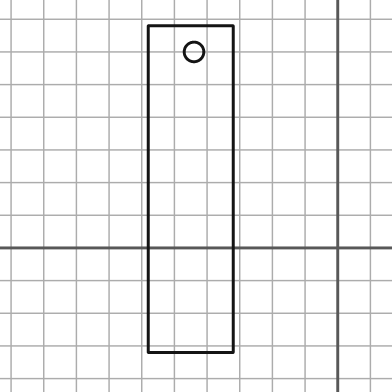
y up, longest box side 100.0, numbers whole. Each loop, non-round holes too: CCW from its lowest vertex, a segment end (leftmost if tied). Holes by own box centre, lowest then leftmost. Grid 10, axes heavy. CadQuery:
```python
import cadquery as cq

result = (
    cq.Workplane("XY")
    .moveTo(-58.0, -32.0)
    .lineTo(-32.0, -32.0)
    .lineTo(-32.0, 68.0)
    .lineTo(-58.0, 68.0)
    .close()
    .moveTo(-44.0, 60.0)
    .circle(3.0)
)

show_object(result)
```